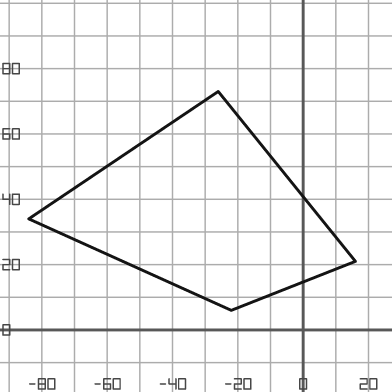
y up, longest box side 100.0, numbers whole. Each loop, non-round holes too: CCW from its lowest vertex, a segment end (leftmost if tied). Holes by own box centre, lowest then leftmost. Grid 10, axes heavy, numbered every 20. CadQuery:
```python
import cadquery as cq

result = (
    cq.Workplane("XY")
    .moveTo(-22.0, 6.0)
    .lineTo(16.0, 21.0)
    .lineTo(-26.0, 73.0)
    .lineTo(-84.0, 34.0)
    .close()
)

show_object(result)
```